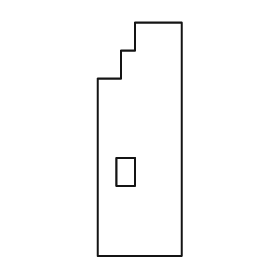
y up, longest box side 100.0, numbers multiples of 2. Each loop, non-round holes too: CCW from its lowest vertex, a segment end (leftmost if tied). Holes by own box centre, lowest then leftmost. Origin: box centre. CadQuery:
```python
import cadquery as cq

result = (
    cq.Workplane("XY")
    .moveTo(-18.0, -50.0)
    .lineTo(18.0, -50.0)
    .lineTo(18.0, 50.0)
    .lineTo(-2.0, 50.0)
    .lineTo(-2.0, 38.0)
    .lineTo(-8.0, 38.0)
    .lineTo(-8.0, 26.0)
    .lineTo(-18.0, 26.0)
    .close()
    .moveTo(-10.0, -20.0)
    .lineTo(-2.0, -20.0)
    .lineTo(-2.0, -8.0)
    .lineTo(-10.0, -8.0)
    .close()
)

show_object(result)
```